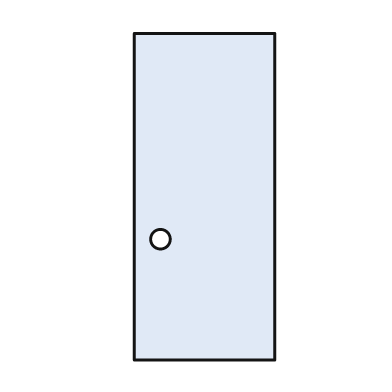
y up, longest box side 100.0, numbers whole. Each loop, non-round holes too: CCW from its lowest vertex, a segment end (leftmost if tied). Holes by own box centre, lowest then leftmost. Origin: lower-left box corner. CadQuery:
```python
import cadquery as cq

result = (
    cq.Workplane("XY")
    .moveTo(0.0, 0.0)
    .lineTo(43.0, 0.0)
    .lineTo(43.0, 100.0)
    .lineTo(0.0, 100.0)
    .close()
    .moveTo(8.0, 37.0)
    .circle(3.0)
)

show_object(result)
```